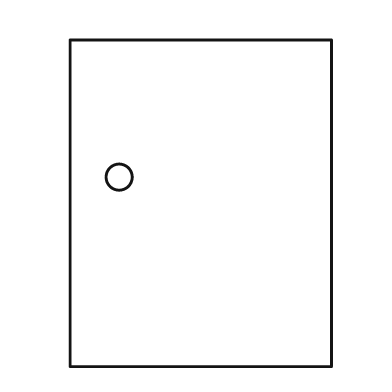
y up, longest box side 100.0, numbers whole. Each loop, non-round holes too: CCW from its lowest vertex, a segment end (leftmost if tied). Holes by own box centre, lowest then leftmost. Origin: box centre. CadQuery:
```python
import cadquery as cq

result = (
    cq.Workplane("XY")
    .moveTo(-40.0, -50.0)
    .lineTo(40.0, -50.0)
    .lineTo(40.0, 50.0)
    .lineTo(-40.0, 50.0)
    .close()
    .moveTo(-25.0, 8.0)
    .circle(4.0)
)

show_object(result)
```